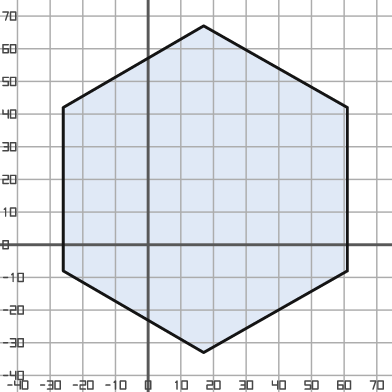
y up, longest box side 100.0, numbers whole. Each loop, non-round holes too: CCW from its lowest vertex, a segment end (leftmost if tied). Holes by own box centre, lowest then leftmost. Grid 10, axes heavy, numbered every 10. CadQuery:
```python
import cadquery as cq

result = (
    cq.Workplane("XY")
    .moveTo(17.0, -33.0)
    .lineTo(61.0, -8.0)
    .lineTo(61.0, 42.0)
    .lineTo(17.0, 67.0)
    .lineTo(-26.0, 42.0)
    .lineTo(-26.0, -8.0)
    .close()
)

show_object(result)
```